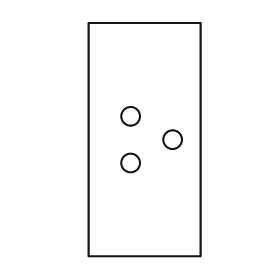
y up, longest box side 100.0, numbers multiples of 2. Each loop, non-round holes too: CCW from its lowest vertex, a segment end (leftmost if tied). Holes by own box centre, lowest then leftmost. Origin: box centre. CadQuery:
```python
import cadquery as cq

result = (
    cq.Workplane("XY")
    .moveTo(-24.0, -50.0)
    .lineTo(24.0, -50.0)
    .lineTo(24.0, 50.0)
    .lineTo(-24.0, 50.0)
    .close()
    .moveTo(-6.0, -10.0)
    .circle(4.0)
    .moveTo(12.0, 0.0)
    .circle(4.0)
    .moveTo(-6.0, 10.0)
    .circle(4.0)
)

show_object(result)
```